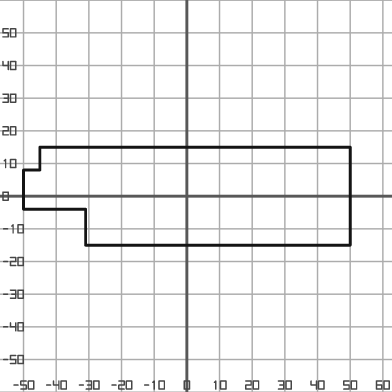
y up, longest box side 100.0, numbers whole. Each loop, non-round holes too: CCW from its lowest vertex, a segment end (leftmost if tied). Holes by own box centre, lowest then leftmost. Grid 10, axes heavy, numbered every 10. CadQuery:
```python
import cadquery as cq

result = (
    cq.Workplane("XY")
    .moveTo(-31.0, -15.0)
    .lineTo(50.0, -15.0)
    .lineTo(50.0, 15.0)
    .lineTo(-45.0, 15.0)
    .lineTo(-45.0, 8.0)
    .lineTo(-50.0, 8.0)
    .lineTo(-50.0, -4.0)
    .lineTo(-31.0, -4.0)
    .close()
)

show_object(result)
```